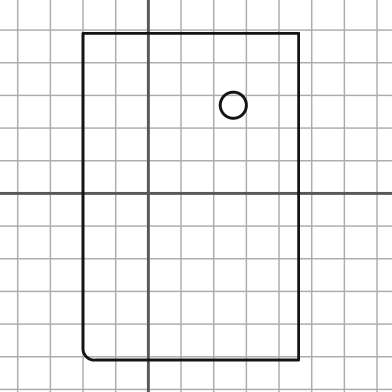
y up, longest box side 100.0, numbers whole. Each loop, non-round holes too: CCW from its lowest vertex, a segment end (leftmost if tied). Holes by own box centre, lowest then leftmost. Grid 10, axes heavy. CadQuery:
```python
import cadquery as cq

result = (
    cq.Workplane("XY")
    .moveTo(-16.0, -51.0)
    .lineTo(46.0, -51.0)
    .lineTo(46.0, 49.0)
    .lineTo(-20.0, 49.0)
    .lineTo(-20.0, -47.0)
    .threePointArc((-19.0, -50.0), (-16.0, -51.0))
    .close()
    .moveTo(26.0, 27.0)
    .circle(4.0)
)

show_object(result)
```